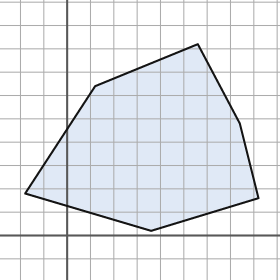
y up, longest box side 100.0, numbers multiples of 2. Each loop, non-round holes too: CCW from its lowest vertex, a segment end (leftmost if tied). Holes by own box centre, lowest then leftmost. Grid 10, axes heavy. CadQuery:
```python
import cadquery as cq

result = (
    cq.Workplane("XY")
    .moveTo(36.0, 2.0)
    .lineTo(82.0, 16.0)
    .lineTo(74.0, 48.0)
    .lineTo(56.0, 82.0)
    .lineTo(12.0, 64.0)
    .lineTo(-18.0, 18.0)
    .close()
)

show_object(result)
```